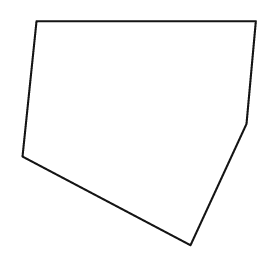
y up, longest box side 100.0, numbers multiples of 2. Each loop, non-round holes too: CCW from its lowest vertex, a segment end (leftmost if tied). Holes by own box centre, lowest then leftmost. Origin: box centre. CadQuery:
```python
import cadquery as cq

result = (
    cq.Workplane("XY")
    .moveTo(22.0, -48.0)
    .lineTo(46.0, 4.0)
    .lineTo(50.0, 48.0)
    .lineTo(-44.0, 48.0)
    .lineTo(-50.0, -10.0)
    .close()
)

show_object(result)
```